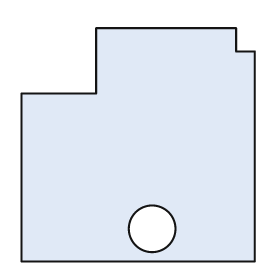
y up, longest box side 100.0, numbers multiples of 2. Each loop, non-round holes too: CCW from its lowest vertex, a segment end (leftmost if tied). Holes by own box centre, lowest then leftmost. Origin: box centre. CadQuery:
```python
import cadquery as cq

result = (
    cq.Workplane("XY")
    .moveTo(-50.0, -50.0)
    .lineTo(50.0, -50.0)
    .lineTo(50.0, 40.0)
    .lineTo(42.0, 40.0)
    .lineTo(42.0, 50.0)
    .lineTo(-18.0, 50.0)
    .lineTo(-18.0, 22.0)
    .lineTo(-50.0, 22.0)
    .close()
    .moveTo(6.0, -36.0)
    .circle(10.0)
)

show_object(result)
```